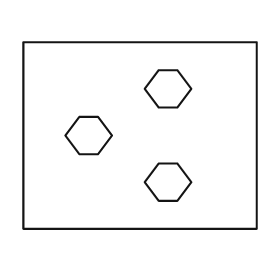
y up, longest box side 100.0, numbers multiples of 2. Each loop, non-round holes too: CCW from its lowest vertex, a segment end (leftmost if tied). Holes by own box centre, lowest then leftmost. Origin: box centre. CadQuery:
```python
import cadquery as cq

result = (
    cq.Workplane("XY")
    .moveTo(-50.0, -40.0)
    .lineTo(50.0, -40.0)
    .lineTo(50.0, 40.0)
    .lineTo(-50.0, 40.0)
    .close()
    .moveTo(8.0, -28.0)
    .lineTo(16.0, -28.0)
    .lineTo(22.0, -20.0)
    .lineTo(16.0, -12.0)
    .lineTo(8.0, -12.0)
    .lineTo(2.0, -20.0)
    .close()
    .moveTo(-26.0, -8.0)
    .lineTo(-18.0, -8.0)
    .lineTo(-12.0, 0.0)
    .lineTo(-18.0, 8.0)
    .lineTo(-26.0, 8.0)
    .lineTo(-32.0, 0.0)
    .close()
    .moveTo(8.0, 12.0)
    .lineTo(16.0, 12.0)
    .lineTo(22.0, 20.0)
    .lineTo(16.0, 28.0)
    .lineTo(8.0, 28.0)
    .lineTo(2.0, 20.0)
    .close()
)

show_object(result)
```